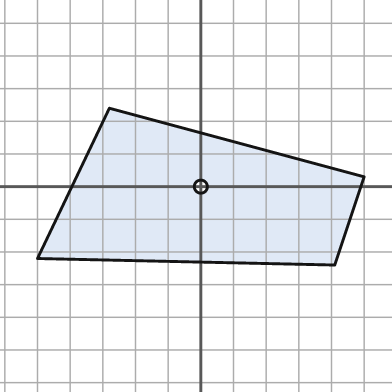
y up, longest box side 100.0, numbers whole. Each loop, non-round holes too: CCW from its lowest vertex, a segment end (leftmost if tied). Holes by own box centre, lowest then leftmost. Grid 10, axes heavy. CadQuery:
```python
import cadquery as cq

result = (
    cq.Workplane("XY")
    .moveTo(41.0, -24.0)
    .lineTo(50.0, 3.0)
    .lineTo(-28.0, 24.0)
    .lineTo(-50.0, -22.0)
    .close()
    .moveTo(0.0, 0.0)
    .circle(2.0)
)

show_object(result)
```